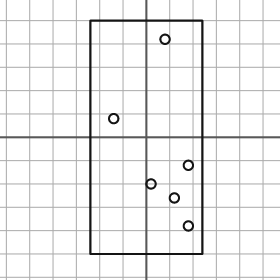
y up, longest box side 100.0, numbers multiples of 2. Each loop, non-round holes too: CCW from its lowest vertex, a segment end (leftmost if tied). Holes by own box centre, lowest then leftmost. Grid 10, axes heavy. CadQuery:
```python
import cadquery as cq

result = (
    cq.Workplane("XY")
    .moveTo(-24.0, -50.0)
    .lineTo(24.0, -50.0)
    .lineTo(24.0, 50.0)
    .lineTo(-24.0, 50.0)
    .close()
    .moveTo(18.0, -38.0)
    .circle(2.0)
    .moveTo(12.0, -26.0)
    .circle(2.0)
    .moveTo(2.0, -20.0)
    .circle(2.0)
    .moveTo(18.0, -12.0)
    .circle(2.0)
    .moveTo(-14.0, 8.0)
    .circle(2.0)
    .moveTo(8.0, 42.0)
    .circle(2.0)
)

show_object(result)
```